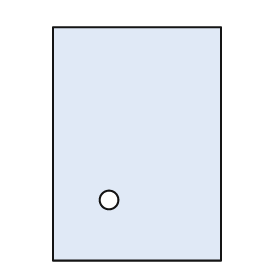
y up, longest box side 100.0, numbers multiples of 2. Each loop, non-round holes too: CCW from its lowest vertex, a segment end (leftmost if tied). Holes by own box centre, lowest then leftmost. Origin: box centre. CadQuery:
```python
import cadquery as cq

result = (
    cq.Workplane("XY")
    .moveTo(-36.0, -50.0)
    .lineTo(36.0, -50.0)
    .lineTo(36.0, 50.0)
    .lineTo(-36.0, 50.0)
    .close()
    .moveTo(-12.0, -24.0)
    .circle(4.0)
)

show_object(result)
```